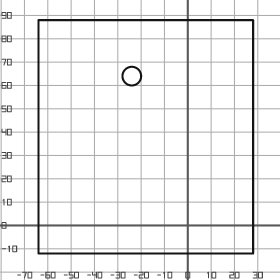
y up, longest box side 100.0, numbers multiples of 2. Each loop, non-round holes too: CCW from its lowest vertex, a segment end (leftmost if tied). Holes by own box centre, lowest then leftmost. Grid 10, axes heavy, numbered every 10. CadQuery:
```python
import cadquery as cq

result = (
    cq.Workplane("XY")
    .moveTo(-64.0, -12.0)
    .lineTo(28.0, -12.0)
    .lineTo(28.0, 88.0)
    .lineTo(-64.0, 88.0)
    .close()
    .moveTo(-24.0, 64.0)
    .circle(4.0)
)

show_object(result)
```